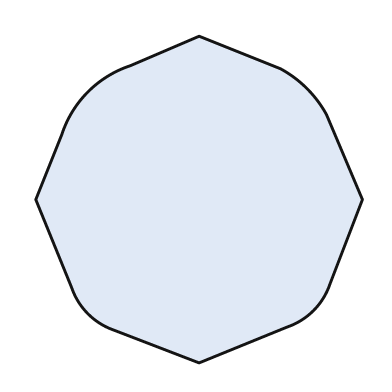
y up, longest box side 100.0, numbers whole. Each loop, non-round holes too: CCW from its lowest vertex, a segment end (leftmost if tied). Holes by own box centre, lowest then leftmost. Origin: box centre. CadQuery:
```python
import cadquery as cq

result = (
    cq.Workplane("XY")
    .moveTo(0.0, -50.0)
    .lineTo(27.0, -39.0)
    .threePointArc((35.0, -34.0), (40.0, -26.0))
    .lineTo(50.0, 0.0)
    .lineTo(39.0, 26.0)
    .threePointArc((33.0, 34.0), (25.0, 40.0))
    .lineTo(0.0, 50.0)
    .lineTo(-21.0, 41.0)
    .threePointArc((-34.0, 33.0), (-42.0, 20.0))
    .lineTo(-50.0, 0.0)
    .lineTo(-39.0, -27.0)
    .threePointArc((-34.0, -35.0), (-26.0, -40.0))
    .close()
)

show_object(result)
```